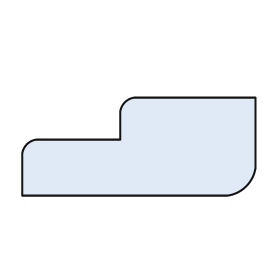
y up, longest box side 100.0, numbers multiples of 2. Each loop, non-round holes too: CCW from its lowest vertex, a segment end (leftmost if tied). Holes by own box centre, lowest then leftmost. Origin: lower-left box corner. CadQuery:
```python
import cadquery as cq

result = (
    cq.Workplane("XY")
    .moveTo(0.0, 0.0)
    .lineTo(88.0, 0.0)
    .threePointArc((96.0, 4.0), (100.0, 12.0))
    .lineTo(100.0, 42.0)
    .lineTo(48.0, 42.0)
    .threePointArc((44.0, 40.0), (42.0, 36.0))
    .lineTo(42.0, 24.0)
    .lineTo(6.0, 24.0)
    .threePointArc((2.0, 22.0), (0.0, 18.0))
    .close()
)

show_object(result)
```